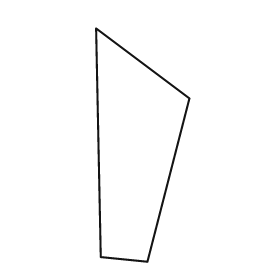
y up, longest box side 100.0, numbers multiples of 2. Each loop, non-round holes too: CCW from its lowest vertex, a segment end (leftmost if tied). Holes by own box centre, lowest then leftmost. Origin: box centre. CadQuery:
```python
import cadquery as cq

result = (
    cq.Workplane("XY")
    .moveTo(2.0, -50.0)
    .lineTo(20.0, 20.0)
    .lineTo(-20.0, 50.0)
    .lineTo(-18.0, -48.0)
    .close()
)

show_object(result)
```